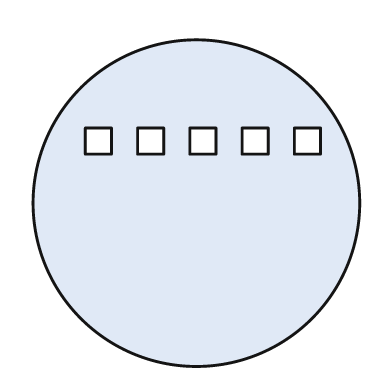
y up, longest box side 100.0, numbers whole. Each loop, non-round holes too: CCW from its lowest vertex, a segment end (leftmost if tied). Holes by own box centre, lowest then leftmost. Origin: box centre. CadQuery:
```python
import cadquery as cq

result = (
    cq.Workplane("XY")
    .moveTo(0.0, 0.0)
    .circle(50.0)
    .moveTo(-34.0, 15.0)
    .lineTo(-26.0, 15.0)
    .lineTo(-26.0, 23.0)
    .lineTo(-34.0, 23.0)
    .close()
    .moveTo(-18.0, 15.0)
    .lineTo(-10.0, 15.0)
    .lineTo(-10.0, 23.0)
    .lineTo(-18.0, 23.0)
    .close()
    .moveTo(-2.0, 15.0)
    .lineTo(6.0, 15.0)
    .lineTo(6.0, 23.0)
    .lineTo(-2.0, 23.0)
    .close()
    .moveTo(14.0, 15.0)
    .lineTo(22.0, 15.0)
    .lineTo(22.0, 23.0)
    .lineTo(14.0, 23.0)
    .close()
    .moveTo(30.0, 15.0)
    .lineTo(38.0, 15.0)
    .lineTo(38.0, 23.0)
    .lineTo(30.0, 23.0)
    .close()
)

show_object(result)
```